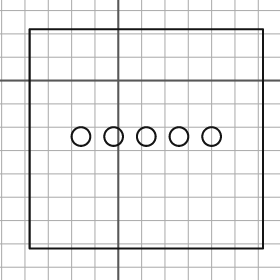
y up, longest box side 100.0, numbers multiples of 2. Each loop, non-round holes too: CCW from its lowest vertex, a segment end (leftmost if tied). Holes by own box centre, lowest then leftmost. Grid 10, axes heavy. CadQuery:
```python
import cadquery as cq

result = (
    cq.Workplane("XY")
    .moveTo(-38.0, -72.0)
    .lineTo(62.0, -72.0)
    .lineTo(62.0, 22.0)
    .lineTo(-38.0, 22.0)
    .close()
    .moveTo(-16.0, -24.0)
    .circle(4.0)
    .moveTo(-2.0, -24.0)
    .circle(4.0)
    .moveTo(12.0, -24.0)
    .circle(4.0)
    .moveTo(26.0, -24.0)
    .circle(4.0)
    .moveTo(40.0, -24.0)
    .circle(4.0)
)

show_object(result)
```